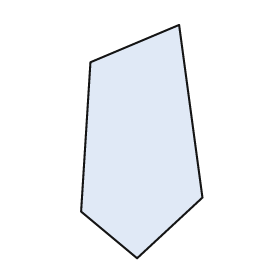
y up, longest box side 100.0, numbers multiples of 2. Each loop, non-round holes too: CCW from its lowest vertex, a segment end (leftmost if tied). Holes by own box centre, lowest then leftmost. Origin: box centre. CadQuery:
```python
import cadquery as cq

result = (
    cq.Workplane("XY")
    .moveTo(-2.0, -50.0)
    .lineTo(26.0, -24.0)
    .lineTo(16.0, 50.0)
    .lineTo(-22.0, 34.0)
    .lineTo(-26.0, -30.0)
    .close()
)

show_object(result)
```